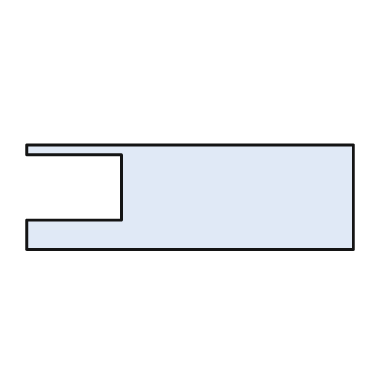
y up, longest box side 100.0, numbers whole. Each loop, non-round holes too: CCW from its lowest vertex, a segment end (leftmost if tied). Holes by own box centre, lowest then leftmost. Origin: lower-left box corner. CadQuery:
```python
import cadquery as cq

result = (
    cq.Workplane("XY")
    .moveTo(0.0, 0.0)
    .lineTo(100.0, 0.0)
    .lineTo(100.0, 32.0)
    .lineTo(0.0, 32.0)
    .lineTo(0.0, 29.0)
    .lineTo(29.0, 29.0)
    .lineTo(29.0, 9.0)
    .lineTo(0.0, 9.0)
    .close()
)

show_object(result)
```